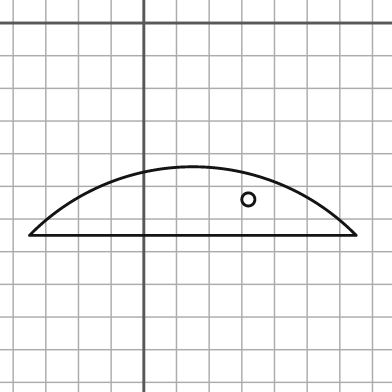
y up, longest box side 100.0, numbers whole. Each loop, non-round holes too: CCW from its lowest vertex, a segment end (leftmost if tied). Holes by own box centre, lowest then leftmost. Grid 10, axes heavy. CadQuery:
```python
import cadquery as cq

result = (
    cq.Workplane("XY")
    .moveTo(-35.0, -65.0)
    .lineTo(65.0, -65.0)
    .threePointArc((15.0, -44.0), (-35.0, -65.0))
    .close()
    .moveTo(32.0, -54.0)
    .circle(2.0)
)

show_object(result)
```